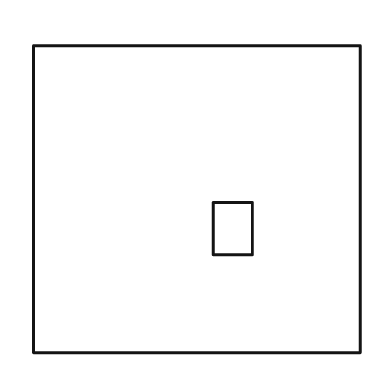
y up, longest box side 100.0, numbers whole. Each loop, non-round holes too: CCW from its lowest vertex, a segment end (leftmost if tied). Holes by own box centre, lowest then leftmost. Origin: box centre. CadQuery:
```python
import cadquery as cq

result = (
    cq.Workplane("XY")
    .moveTo(-50.0, -47.0)
    .lineTo(50.0, -47.0)
    .lineTo(50.0, 47.0)
    .lineTo(-50.0, 47.0)
    .close()
    .moveTo(5.0, -17.0)
    .lineTo(17.0, -17.0)
    .lineTo(17.0, -1.0)
    .lineTo(5.0, -1.0)
    .close()
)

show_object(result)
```